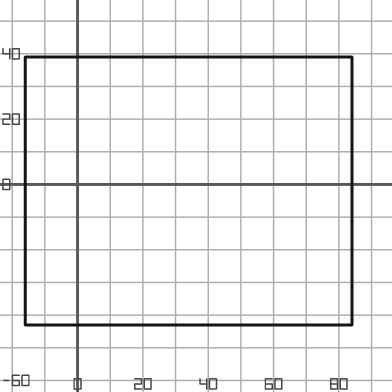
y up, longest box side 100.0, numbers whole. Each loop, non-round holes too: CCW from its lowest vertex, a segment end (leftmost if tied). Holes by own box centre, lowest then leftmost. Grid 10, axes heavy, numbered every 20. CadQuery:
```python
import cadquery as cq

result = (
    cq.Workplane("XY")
    .moveTo(-16.0, -43.0)
    .lineTo(84.0, -43.0)
    .lineTo(84.0, 39.0)
    .lineTo(-16.0, 39.0)
    .close()
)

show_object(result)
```